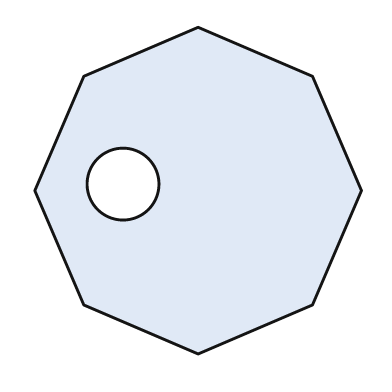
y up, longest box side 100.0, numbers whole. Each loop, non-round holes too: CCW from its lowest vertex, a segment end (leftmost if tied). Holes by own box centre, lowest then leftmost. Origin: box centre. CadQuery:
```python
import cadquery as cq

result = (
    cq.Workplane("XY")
    .moveTo(0.0, -50.0)
    .lineTo(35.0, -35.0)
    .lineTo(50.0, 0.0)
    .lineTo(35.0, 35.0)
    .lineTo(0.0, 50.0)
    .lineTo(-35.0, 35.0)
    .lineTo(-50.0, 0.0)
    .lineTo(-35.0, -35.0)
    .close()
    .moveTo(-23.0, 2.0)
    .circle(11.0)
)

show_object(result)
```